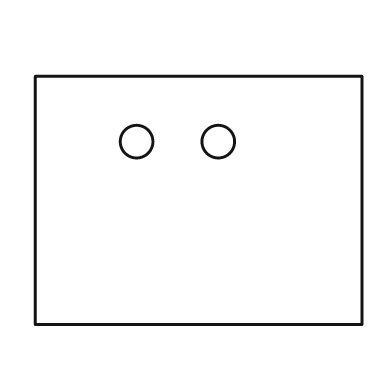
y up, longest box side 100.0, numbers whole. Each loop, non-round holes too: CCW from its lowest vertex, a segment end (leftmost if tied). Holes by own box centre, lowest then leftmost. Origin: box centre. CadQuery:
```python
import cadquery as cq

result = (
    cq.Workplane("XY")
    .moveTo(-50.0, -38.0)
    .lineTo(50.0, -38.0)
    .lineTo(50.0, 38.0)
    .lineTo(-50.0, 38.0)
    .close()
    .moveTo(-19.0, 18.0)
    .circle(5.0)
    .moveTo(6.0, 18.0)
    .circle(5.0)
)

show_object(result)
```